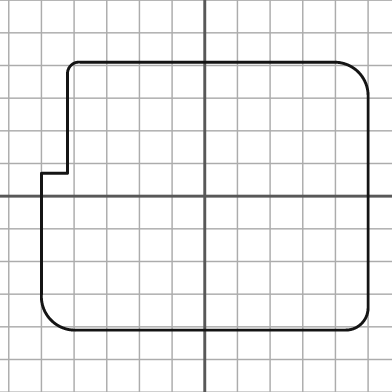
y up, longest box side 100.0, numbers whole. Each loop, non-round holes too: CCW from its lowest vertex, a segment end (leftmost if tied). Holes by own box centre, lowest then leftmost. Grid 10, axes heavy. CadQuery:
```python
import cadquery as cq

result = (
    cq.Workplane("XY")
    .moveTo(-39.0, -41.0)
    .lineTo(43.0, -41.0)
    .threePointArc((48.0, -39.0), (50.0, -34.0))
    .lineTo(50.0, 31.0)
    .threePointArc((47.0, 38.0), (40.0, 41.0))
    .lineTo(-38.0, 41.0)
    .threePointArc((-41.0, 40.0), (-42.0, 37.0))
    .lineTo(-42.0, 7.0)
    .lineTo(-50.0, 7.0)
    .lineTo(-50.0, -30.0)
    .threePointArc((-47.0, -38.0), (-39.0, -41.0))
    .close()
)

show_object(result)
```